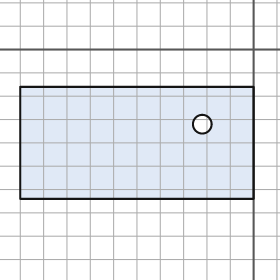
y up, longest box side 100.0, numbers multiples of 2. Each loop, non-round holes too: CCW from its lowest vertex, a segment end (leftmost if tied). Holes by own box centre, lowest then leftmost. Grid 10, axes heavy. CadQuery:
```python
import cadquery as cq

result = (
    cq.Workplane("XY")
    .moveTo(-100.0, -64.0)
    .lineTo(0.0, -64.0)
    .lineTo(0.0, -16.0)
    .lineTo(-100.0, -16.0)
    .close()
    .moveTo(-22.0, -32.0)
    .circle(4.0)
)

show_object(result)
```